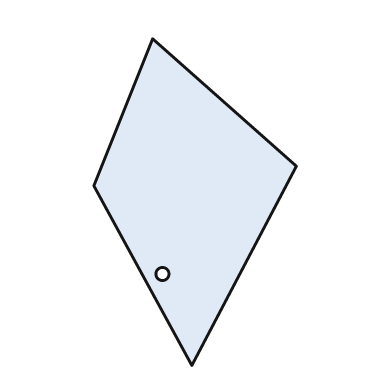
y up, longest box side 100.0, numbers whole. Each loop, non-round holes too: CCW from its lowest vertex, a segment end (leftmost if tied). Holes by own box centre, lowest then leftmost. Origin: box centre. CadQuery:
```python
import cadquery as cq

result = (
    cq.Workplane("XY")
    .moveTo(-1.0, -50.0)
    .lineTo(31.0, 11.0)
    .lineTo(-13.0, 50.0)
    .lineTo(-31.0, 5.0)
    .close()
    .moveTo(-10.0, -22.0)
    .circle(2.0)
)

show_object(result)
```